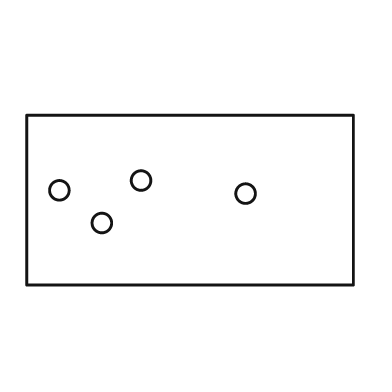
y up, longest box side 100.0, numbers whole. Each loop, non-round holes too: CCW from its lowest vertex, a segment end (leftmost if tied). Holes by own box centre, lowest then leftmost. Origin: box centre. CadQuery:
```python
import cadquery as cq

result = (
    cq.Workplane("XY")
    .moveTo(-50.0, -26.0)
    .lineTo(50.0, -26.0)
    .lineTo(50.0, 26.0)
    .lineTo(-50.0, 26.0)
    .close()
    .moveTo(-27.0, -7.0)
    .circle(3.0)
    .moveTo(17.0, 2.0)
    .circle(3.0)
    .moveTo(-40.0, 3.0)
    .circle(3.0)
    .moveTo(-15.0, 6.0)
    .circle(3.0)
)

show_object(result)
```